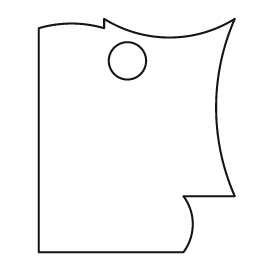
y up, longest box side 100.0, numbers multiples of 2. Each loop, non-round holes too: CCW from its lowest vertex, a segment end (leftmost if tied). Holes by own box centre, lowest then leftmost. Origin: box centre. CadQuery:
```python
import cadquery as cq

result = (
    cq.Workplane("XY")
    .moveTo(-42.0, -50.0)
    .lineTo(20.0, -50.0)
    .threePointArc((24.0, -38.0), (20.0, -26.0))
    .lineTo(42.0, -26.0)
    .threePointArc((34.0, 12.0), (42.0, 50.0))
    .threePointArc((14.0, 42.0), (-14.0, 50.0))
    .lineTo(-14.0, 46.0)
    .threePointArc((-28.0, 48.0), (-42.0, 46.0))
    .close()
    .moveTo(-4.0, 32.0)
    .circle(8.0)
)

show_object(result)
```